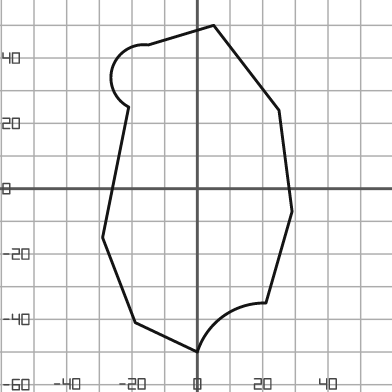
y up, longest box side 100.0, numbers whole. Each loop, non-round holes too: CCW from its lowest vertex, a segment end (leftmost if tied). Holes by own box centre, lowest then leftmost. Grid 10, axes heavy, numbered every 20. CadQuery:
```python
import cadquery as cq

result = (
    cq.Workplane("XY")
    .moveTo(0.0, -50.0)
    .threePointArc((8.0, -39.0), (21.0, -35.0))
    .lineTo(29.0, -7.0)
    .lineTo(25.0, 24.0)
    .lineTo(5.0, 50.0)
    .lineTo(-15.0, 44.0)
    .threePointArc((-26.0, 37.0), (-21.0, 25.0))
    .lineTo(-29.0, -15.0)
    .lineTo(-19.0, -41.0)
    .close()
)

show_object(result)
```